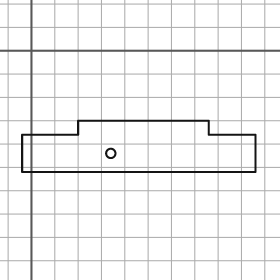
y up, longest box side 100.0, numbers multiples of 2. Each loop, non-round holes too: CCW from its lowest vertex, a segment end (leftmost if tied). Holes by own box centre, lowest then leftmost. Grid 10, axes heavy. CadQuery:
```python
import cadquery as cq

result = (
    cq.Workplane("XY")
    .moveTo(-4.0, -52.0)
    .lineTo(96.0, -52.0)
    .lineTo(96.0, -36.0)
    .lineTo(76.0, -36.0)
    .lineTo(76.0, -30.0)
    .lineTo(20.0, -30.0)
    .lineTo(20.0, -36.0)
    .lineTo(-4.0, -36.0)
    .close()
    .moveTo(34.0, -44.0)
    .circle(2.0)
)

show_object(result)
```